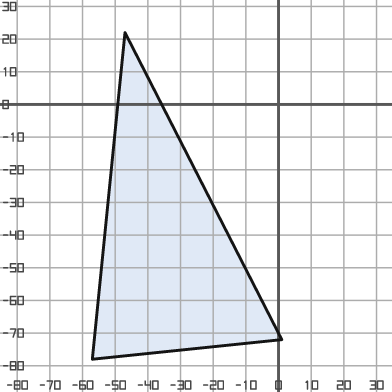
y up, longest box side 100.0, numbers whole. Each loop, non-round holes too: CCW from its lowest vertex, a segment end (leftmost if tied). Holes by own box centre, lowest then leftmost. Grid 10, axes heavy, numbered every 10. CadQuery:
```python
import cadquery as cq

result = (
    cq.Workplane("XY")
    .moveTo(-57.0, -78.0)
    .lineTo(1.0, -72.0)
    .lineTo(-47.0, 22.0)
    .close()
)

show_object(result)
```